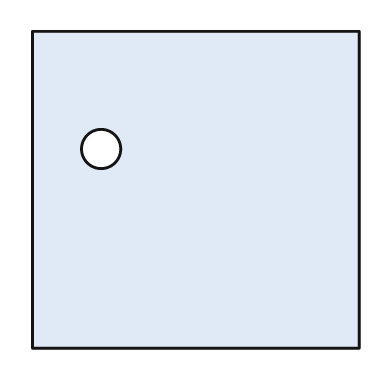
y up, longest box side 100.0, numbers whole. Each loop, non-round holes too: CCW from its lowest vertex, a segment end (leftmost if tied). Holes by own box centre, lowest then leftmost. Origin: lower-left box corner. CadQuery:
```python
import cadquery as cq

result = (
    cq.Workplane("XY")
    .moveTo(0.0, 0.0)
    .lineTo(100.0, 0.0)
    .lineTo(100.0, 97.0)
    .lineTo(0.0, 97.0)
    .close()
    .moveTo(21.0, 61.0)
    .circle(6.0)
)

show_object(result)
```